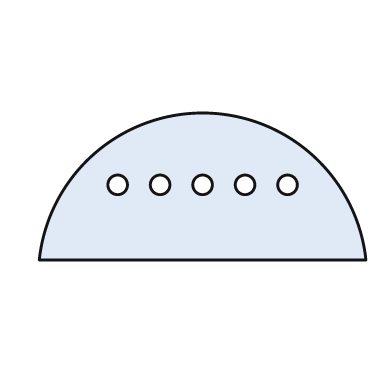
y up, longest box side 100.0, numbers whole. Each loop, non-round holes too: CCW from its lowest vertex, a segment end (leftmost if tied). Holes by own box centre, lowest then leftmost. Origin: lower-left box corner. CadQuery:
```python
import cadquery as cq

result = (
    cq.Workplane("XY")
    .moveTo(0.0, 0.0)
    .lineTo(100.0, 0.0)
    .threePointArc((50.0, 45.0), (0.0, 0.0))
    .close()
    .moveTo(24.0, 23.0)
    .circle(3.0)
    .moveTo(37.0, 23.0)
    .circle(3.0)
    .moveTo(50.0, 23.0)
    .circle(3.0)
    .moveTo(63.0, 23.0)
    .circle(3.0)
    .moveTo(76.0, 23.0)
    .circle(3.0)
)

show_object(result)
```